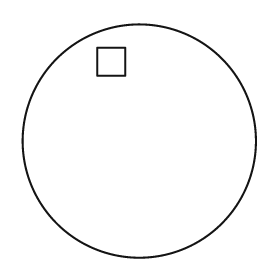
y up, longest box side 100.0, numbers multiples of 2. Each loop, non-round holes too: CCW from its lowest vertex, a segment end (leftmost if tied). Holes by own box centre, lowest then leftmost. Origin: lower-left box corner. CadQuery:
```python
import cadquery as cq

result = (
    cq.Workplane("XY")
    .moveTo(50.0, 50.0)
    .circle(50.0)
    .moveTo(32.0, 78.0)
    .lineTo(44.0, 78.0)
    .lineTo(44.0, 90.0)
    .lineTo(32.0, 90.0)
    .close()
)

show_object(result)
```